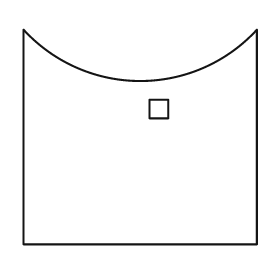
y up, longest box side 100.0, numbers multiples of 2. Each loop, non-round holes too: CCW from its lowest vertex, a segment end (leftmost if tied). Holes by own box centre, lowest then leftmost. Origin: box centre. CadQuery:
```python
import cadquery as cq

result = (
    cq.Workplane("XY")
    .moveTo(-50.0, -46.0)
    .lineTo(50.0, -46.0)
    .lineTo(50.0, 46.0)
    .threePointArc((0.0, 24.0), (-50.0, 46.0))
    .close()
    .moveTo(4.0, 8.0)
    .lineTo(12.0, 8.0)
    .lineTo(12.0, 16.0)
    .lineTo(4.0, 16.0)
    .close()
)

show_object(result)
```